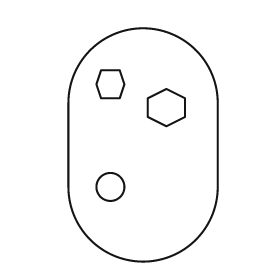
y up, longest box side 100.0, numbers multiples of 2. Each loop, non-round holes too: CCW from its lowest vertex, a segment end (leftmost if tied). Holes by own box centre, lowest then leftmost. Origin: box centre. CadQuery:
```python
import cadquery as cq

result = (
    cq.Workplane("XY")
    .moveTo(-32.0, -18.0)
    .threePointArc((0.0, -50.0), (32.0, -18.0))
    .lineTo(32.0, 18.0)
    .threePointArc((0.0, 50.0), (-32.0, 18.0))
    .close()
    .moveTo(-14.0, -18.0)
    .circle(6.0)
    .moveTo(10.0, 8.0)
    .lineTo(18.0, 12.0)
    .lineTo(18.0, 20.0)
    .lineTo(10.0, 24.0)
    .lineTo(2.0, 20.0)
    .lineTo(2.0, 12.0)
    .close()
    .moveTo(-18.0, 20.0)
    .lineTo(-10.0, 20.0)
    .lineTo(-8.0, 26.0)
    .lineTo(-10.0, 32.0)
    .lineTo(-18.0, 32.0)
    .lineTo(-20.0, 26.0)
    .close()
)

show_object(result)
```